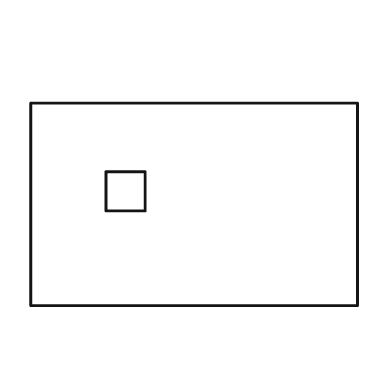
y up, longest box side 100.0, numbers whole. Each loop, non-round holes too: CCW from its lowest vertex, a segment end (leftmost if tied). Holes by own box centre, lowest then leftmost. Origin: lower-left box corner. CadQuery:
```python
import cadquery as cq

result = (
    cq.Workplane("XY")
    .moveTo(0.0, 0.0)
    .lineTo(100.0, 0.0)
    .lineTo(100.0, 62.0)
    .lineTo(0.0, 62.0)
    .close()
    .moveTo(23.0, 29.0)
    .lineTo(35.0, 29.0)
    .lineTo(35.0, 41.0)
    .lineTo(23.0, 41.0)
    .close()
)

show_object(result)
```